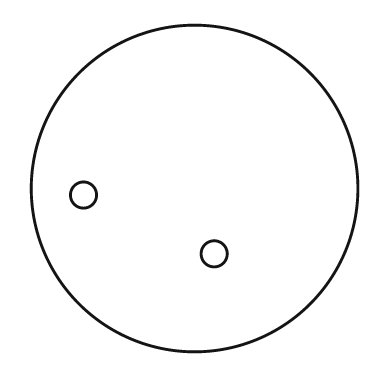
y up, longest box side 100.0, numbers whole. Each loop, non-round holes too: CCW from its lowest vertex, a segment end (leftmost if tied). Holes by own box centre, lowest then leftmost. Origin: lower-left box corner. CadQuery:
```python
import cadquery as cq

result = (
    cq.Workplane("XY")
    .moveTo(50.0, 50.0)
    .circle(50.0)
    .moveTo(56.0, 30.0)
    .circle(4.0)
    .moveTo(16.0, 48.0)
    .circle(4.0)
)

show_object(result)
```